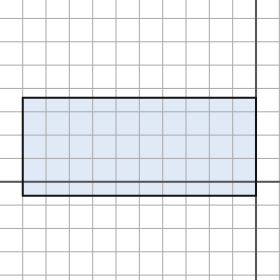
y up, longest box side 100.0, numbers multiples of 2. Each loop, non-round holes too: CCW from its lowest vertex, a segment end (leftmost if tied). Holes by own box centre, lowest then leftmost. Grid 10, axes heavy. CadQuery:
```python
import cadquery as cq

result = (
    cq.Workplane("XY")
    .moveTo(-100.0, -6.0)
    .lineTo(0.0, -6.0)
    .lineTo(0.0, 36.0)
    .lineTo(-100.0, 36.0)
    .close()
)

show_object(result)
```